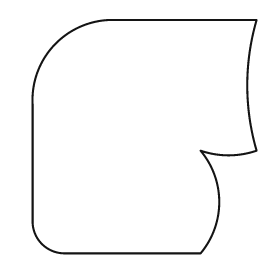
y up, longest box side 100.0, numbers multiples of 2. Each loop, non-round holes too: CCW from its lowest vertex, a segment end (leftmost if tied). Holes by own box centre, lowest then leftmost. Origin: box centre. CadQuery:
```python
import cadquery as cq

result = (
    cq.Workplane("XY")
    .moveTo(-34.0, -50.0)
    .lineTo(24.0, -50.0)
    .threePointArc((32.0, -28.0), (24.0, -6.0))
    .threePointArc((36.0, -8.0), (48.0, -6.0))
    .threePointArc((44.0, 22.0), (48.0, 50.0))
    .lineTo(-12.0, 50.0)
    .threePointArc((-38.0, 40.0), (-48.0, 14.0))
    .lineTo(-48.0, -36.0)
    .threePointArc((-44.0, -46.0), (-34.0, -50.0))
    .close()
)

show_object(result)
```